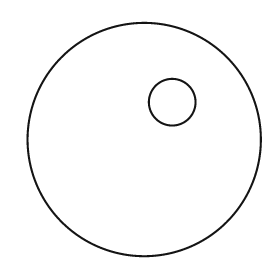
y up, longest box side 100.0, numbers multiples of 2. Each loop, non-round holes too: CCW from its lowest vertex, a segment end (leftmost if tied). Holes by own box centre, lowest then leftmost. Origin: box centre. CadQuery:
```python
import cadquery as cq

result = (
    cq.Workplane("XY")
    .moveTo(0.0, 0.0)
    .circle(50.0)
    .moveTo(12.0, 16.0)
    .circle(10.0)
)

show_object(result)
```